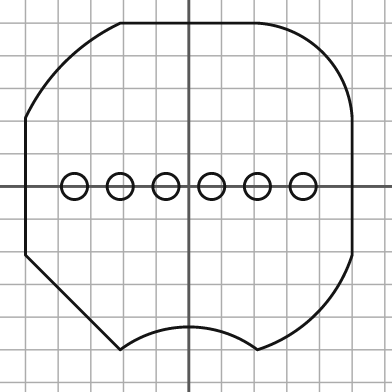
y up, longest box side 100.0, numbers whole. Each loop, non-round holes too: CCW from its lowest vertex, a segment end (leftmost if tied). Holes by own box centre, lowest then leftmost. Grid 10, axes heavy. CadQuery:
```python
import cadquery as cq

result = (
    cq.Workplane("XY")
    .moveTo(-21.0, -50.0)
    .threePointArc((0.0, -43.0), (21.0, -50.0))
    .threePointArc((39.0, -39.0), (50.0, -21.0))
    .lineTo(50.0, 21.0)
    .threePointArc((41.0, 41.0), (21.0, 50.0))
    .lineTo(-21.0, 50.0)
    .threePointArc((-38.0, 38.0), (-50.0, 21.0))
    .lineTo(-50.0, -21.0)
    .close()
    .moveTo(-35.0, 0.0)
    .circle(4.0)
    .moveTo(-21.0, 0.0)
    .circle(4.0)
    .moveTo(-7.0, 0.0)
    .circle(4.0)
    .moveTo(7.0, 0.0)
    .circle(4.0)
    .moveTo(21.0, 0.0)
    .circle(4.0)
    .moveTo(35.0, 0.0)
    .circle(4.0)
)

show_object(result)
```